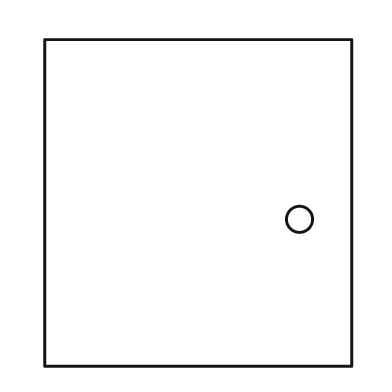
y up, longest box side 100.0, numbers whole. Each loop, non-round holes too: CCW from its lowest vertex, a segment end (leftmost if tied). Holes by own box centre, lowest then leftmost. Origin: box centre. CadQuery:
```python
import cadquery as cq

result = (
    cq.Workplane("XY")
    .moveTo(-47.0, -50.0)
    .lineTo(47.0, -50.0)
    .lineTo(47.0, 50.0)
    .lineTo(-47.0, 50.0)
    .close()
    .moveTo(31.0, -5.0)
    .circle(4.0)
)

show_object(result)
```